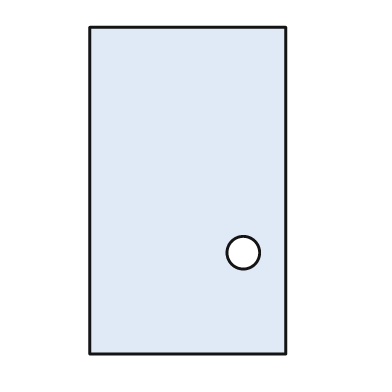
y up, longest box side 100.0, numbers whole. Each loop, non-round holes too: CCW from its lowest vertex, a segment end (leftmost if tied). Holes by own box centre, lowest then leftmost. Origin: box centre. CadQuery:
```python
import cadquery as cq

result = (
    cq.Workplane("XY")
    .moveTo(-30.0, -50.0)
    .lineTo(30.0, -50.0)
    .lineTo(30.0, 50.0)
    .lineTo(-30.0, 50.0)
    .close()
    .moveTo(17.0, -19.0)
    .circle(5.0)
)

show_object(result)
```